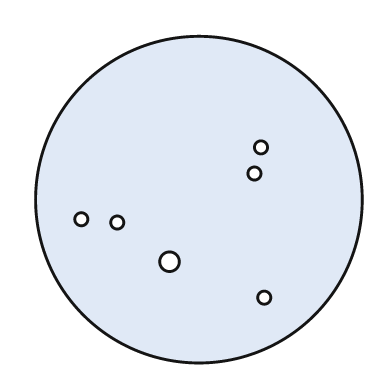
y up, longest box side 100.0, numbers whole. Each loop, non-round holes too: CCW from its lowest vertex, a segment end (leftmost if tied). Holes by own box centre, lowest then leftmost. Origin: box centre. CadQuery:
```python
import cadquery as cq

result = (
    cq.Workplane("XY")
    .moveTo(0.0, 0.0)
    .circle(50.0)
    .moveTo(20.0, -30.0)
    .circle(2.0)
    .moveTo(-9.0, -19.0)
    .circle(3.0)
    .moveTo(-25.0, -7.0)
    .circle(2.0)
    .moveTo(-36.0, -6.0)
    .circle(2.0)
    .moveTo(17.0, 8.0)
    .circle(2.0)
    .moveTo(19.0, 16.0)
    .circle(2.0)
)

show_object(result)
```